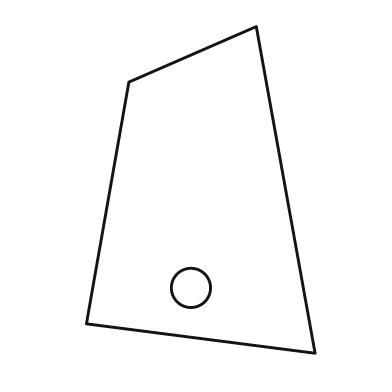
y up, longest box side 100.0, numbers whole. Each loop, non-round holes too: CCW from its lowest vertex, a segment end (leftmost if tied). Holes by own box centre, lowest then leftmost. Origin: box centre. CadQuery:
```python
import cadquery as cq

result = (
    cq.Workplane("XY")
    .moveTo(35.0, -50.0)
    .lineTo(17.0, 50.0)
    .lineTo(-22.0, 33.0)
    .lineTo(-35.0, -41.0)
    .close()
    .moveTo(-3.0, -30.0)
    .circle(6.0)
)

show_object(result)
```